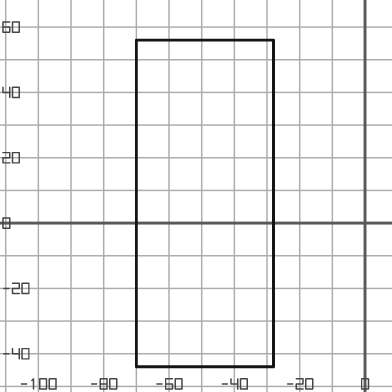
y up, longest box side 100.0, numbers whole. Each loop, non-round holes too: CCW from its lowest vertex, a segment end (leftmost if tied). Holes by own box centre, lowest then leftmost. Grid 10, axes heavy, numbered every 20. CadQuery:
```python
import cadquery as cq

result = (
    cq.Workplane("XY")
    .moveTo(-70.0, -44.0)
    .lineTo(-28.0, -44.0)
    .lineTo(-28.0, 56.0)
    .lineTo(-70.0, 56.0)
    .close()
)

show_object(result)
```